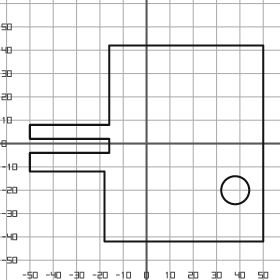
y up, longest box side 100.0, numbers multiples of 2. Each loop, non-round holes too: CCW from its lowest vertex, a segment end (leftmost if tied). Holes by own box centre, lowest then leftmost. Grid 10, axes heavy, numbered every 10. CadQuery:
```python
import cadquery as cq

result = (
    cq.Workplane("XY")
    .moveTo(-18.0, -42.0)
    .lineTo(50.0, -42.0)
    .lineTo(50.0, 42.0)
    .lineTo(-16.0, 42.0)
    .lineTo(-16.0, 8.0)
    .lineTo(-50.0, 8.0)
    .lineTo(-50.0, 2.0)
    .lineTo(-16.0, 2.0)
    .lineTo(-16.0, -4.0)
    .lineTo(-50.0, -4.0)
    .lineTo(-50.0, -12.0)
    .lineTo(-18.0, -12.0)
    .close()
    .moveTo(38.0, -20.0)
    .circle(6.0)
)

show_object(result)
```